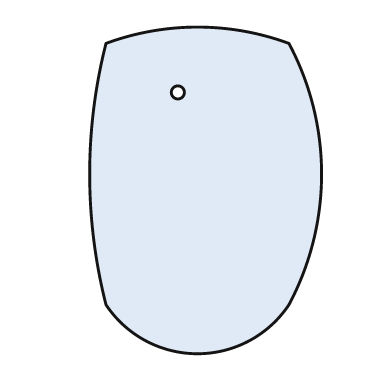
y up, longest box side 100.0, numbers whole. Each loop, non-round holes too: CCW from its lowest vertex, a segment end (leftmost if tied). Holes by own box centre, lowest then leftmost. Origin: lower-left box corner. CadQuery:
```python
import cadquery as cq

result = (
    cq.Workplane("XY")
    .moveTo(5.0, 15.0)
    .threePointArc((33.0, 0.0), (61.0, 15.0))
    .threePointArc((71.0, 55.0), (61.0, 95.0))
    .threePointArc((33.0, 100.0), (5.0, 95.0))
    .threePointArc((0.0, 55.0), (5.0, 15.0))
    .close()
    .moveTo(27.0, 80.0)
    .circle(2.0)
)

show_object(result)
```